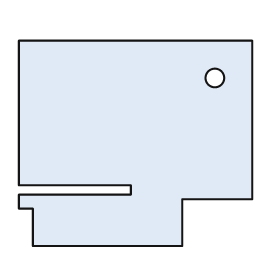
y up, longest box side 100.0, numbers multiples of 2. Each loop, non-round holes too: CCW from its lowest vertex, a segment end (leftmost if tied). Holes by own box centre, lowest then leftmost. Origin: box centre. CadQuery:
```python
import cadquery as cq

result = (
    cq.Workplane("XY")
    .moveTo(-44.0, -44.0)
    .lineTo(20.0, -44.0)
    .lineTo(20.0, -24.0)
    .lineTo(50.0, -24.0)
    .lineTo(50.0, 44.0)
    .lineTo(-50.0, 44.0)
    .lineTo(-50.0, -18.0)
    .lineTo(-2.0, -18.0)
    .lineTo(-2.0, -22.0)
    .lineTo(-50.0, -22.0)
    .lineTo(-50.0, -28.0)
    .lineTo(-44.0, -28.0)
    .close()
    .moveTo(34.0, 28.0)
    .circle(4.0)
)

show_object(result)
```